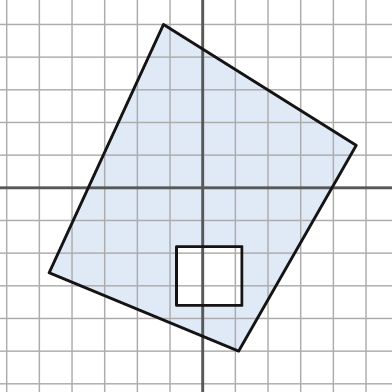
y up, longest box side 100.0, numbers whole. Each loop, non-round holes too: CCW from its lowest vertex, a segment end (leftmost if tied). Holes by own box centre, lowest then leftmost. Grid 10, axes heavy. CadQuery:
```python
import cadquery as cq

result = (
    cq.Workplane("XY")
    .moveTo(11.0, -50.0)
    .lineTo(47.0, 13.0)
    .lineTo(-12.0, 50.0)
    .lineTo(-47.0, -26.0)
    .close()
    .moveTo(-8.0, -36.0)
    .lineTo(12.0, -36.0)
    .lineTo(12.0, -18.0)
    .lineTo(-8.0, -18.0)
    .close()
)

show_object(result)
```